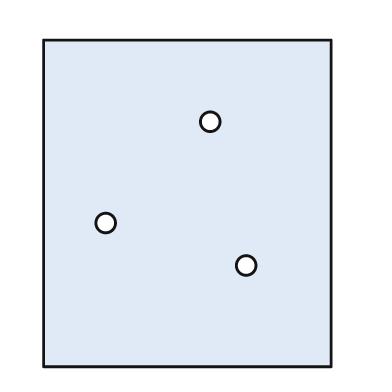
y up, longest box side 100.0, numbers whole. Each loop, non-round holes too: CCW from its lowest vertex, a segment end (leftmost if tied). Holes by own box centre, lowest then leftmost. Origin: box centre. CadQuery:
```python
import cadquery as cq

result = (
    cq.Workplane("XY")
    .moveTo(-44.0, -50.0)
    .lineTo(44.0, -50.0)
    .lineTo(44.0, 50.0)
    .lineTo(-44.0, 50.0)
    .close()
    .moveTo(18.0, -19.0)
    .circle(3.0)
    .moveTo(-25.0, -6.0)
    .circle(3.0)
    .moveTo(7.0, 25.0)
    .circle(3.0)
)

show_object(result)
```